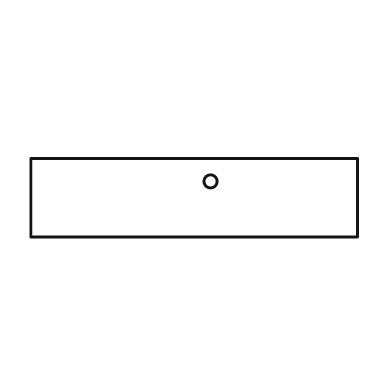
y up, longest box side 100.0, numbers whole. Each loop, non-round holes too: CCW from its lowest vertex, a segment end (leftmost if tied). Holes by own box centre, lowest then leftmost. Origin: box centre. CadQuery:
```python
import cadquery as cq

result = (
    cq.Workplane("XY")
    .moveTo(-50.0, -12.0)
    .lineTo(50.0, -12.0)
    .lineTo(50.0, 12.0)
    .lineTo(-50.0, 12.0)
    .close()
    .moveTo(5.0, 5.0)
    .circle(2.0)
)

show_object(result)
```